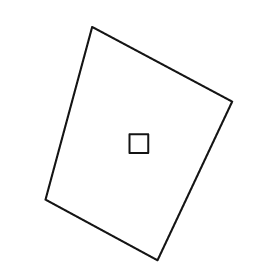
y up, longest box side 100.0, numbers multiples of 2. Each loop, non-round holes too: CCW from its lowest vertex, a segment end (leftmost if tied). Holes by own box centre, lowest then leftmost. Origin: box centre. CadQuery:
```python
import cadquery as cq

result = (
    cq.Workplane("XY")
    .moveTo(8.0, -50.0)
    .lineTo(40.0, 18.0)
    .lineTo(-20.0, 50.0)
    .lineTo(-40.0, -24.0)
    .close()
    .moveTo(-4.0, -4.0)
    .lineTo(4.0, -4.0)
    .lineTo(4.0, 4.0)
    .lineTo(-4.0, 4.0)
    .close()
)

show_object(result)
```